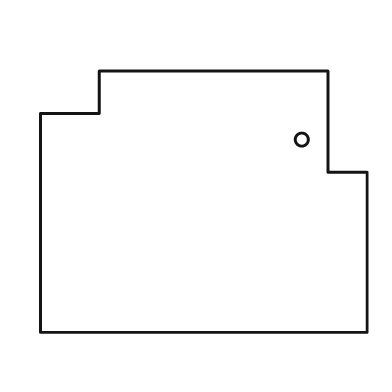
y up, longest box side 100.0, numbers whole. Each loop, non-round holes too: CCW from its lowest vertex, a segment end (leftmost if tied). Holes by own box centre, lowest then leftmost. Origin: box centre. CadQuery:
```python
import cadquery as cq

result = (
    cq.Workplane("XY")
    .moveTo(-50.0, -40.0)
    .lineTo(50.0, -40.0)
    .lineTo(50.0, 9.0)
    .lineTo(38.0, 9.0)
    .lineTo(38.0, 40.0)
    .lineTo(-32.0, 40.0)
    .lineTo(-32.0, 27.0)
    .lineTo(-50.0, 27.0)
    .close()
    .moveTo(30.0, 19.0)
    .circle(2.0)
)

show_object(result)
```